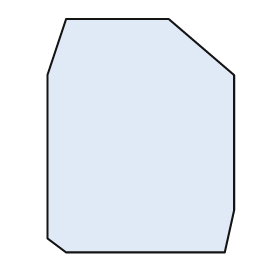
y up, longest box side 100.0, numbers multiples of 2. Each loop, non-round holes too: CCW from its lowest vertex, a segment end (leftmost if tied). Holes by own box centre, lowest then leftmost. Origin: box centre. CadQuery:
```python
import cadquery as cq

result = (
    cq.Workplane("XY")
    .moveTo(-32.0, -50.0)
    .lineTo(36.0, -50.0)
    .lineTo(40.0, -32.0)
    .lineTo(40.0, 26.0)
    .lineTo(12.0, 50.0)
    .lineTo(-32.0, 50.0)
    .lineTo(-40.0, 26.0)
    .lineTo(-40.0, -44.0)
    .close()
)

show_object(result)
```